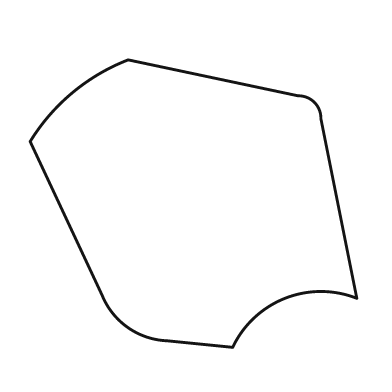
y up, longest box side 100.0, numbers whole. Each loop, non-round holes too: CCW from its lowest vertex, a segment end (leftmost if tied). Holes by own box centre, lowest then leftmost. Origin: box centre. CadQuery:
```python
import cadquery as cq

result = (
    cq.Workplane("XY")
    .moveTo(12.0, -44.0)
    .threePointArc((28.0, -29.0), (50.0, -29.0))
    .lineTo(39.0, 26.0)
    .threePointArc((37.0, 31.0), (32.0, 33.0))
    .lineTo(-20.0, 44.0)
    .threePointArc((-37.0, 34.0), (-50.0, 19.0))
    .lineTo(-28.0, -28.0)
    .threePointArc((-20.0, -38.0), (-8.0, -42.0))
    .close()
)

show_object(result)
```